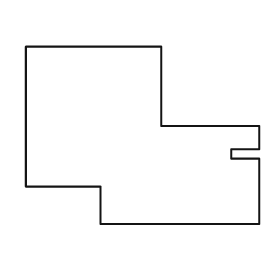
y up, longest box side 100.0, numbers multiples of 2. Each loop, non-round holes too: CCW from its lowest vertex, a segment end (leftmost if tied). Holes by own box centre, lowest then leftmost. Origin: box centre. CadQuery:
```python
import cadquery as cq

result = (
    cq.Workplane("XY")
    .moveTo(-18.0, -38.0)
    .lineTo(50.0, -38.0)
    .lineTo(50.0, -10.0)
    .lineTo(38.0, -10.0)
    .lineTo(38.0, -6.0)
    .lineTo(50.0, -6.0)
    .lineTo(50.0, 4.0)
    .lineTo(8.0, 4.0)
    .lineTo(8.0, 38.0)
    .lineTo(-50.0, 38.0)
    .lineTo(-50.0, -22.0)
    .lineTo(-18.0, -22.0)
    .close()
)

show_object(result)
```